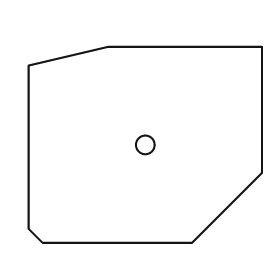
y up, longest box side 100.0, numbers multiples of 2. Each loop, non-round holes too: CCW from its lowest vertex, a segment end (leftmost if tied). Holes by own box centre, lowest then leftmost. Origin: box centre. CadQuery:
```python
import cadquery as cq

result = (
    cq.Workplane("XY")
    .moveTo(-44.0, -42.0)
    .lineTo(20.0, -42.0)
    .lineTo(50.0, -12.0)
    .lineTo(50.0, 42.0)
    .lineTo(-16.0, 42.0)
    .lineTo(-50.0, 34.0)
    .lineTo(-50.0, -36.0)
    .close()
    .moveTo(0.0, 0.0)
    .circle(4.0)
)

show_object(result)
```